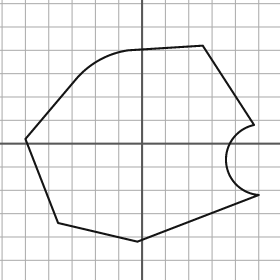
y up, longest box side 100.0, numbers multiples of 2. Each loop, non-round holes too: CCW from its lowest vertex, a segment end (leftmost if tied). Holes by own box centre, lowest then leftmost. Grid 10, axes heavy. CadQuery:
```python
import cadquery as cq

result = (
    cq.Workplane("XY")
    .moveTo(-2.0, -42.0)
    .lineTo(50.0, -22.0)
    .threePointArc((36.0, -8.0), (48.0, 8.0))
    .lineTo(26.0, 42.0)
    .lineTo(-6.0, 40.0)
    .threePointArc((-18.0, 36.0), (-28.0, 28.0))
    .lineTo(-50.0, 2.0)
    .lineTo(-36.0, -34.0)
    .close()
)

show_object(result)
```